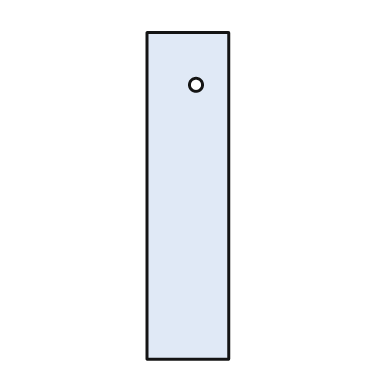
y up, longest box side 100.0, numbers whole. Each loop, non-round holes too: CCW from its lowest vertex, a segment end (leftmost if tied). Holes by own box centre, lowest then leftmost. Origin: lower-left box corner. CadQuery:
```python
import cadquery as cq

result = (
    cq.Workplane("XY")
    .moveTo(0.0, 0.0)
    .lineTo(25.0, 0.0)
    .lineTo(25.0, 100.0)
    .lineTo(0.0, 100.0)
    .close()
    .moveTo(15.0, 84.0)
    .circle(2.0)
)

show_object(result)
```